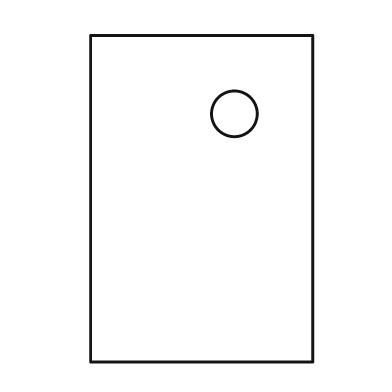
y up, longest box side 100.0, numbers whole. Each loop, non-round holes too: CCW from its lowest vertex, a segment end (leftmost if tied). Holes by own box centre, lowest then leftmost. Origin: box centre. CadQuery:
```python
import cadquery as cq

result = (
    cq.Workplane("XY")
    .moveTo(-34.0, -50.0)
    .lineTo(34.0, -50.0)
    .lineTo(34.0, 50.0)
    .lineTo(-34.0, 50.0)
    .close()
    .moveTo(10.0, 26.0)
    .circle(7.0)
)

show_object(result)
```